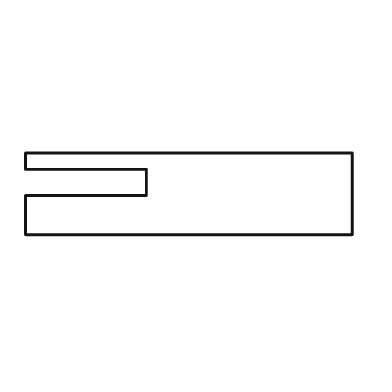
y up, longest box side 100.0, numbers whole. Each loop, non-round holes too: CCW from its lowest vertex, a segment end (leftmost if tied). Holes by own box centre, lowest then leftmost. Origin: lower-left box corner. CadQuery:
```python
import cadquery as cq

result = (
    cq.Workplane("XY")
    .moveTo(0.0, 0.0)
    .lineTo(100.0, 0.0)
    .lineTo(100.0, 25.0)
    .lineTo(0.0, 25.0)
    .lineTo(0.0, 20.0)
    .lineTo(37.0, 20.0)
    .lineTo(37.0, 12.0)
    .lineTo(0.0, 12.0)
    .close()
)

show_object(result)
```